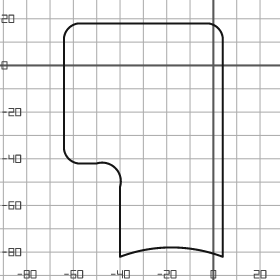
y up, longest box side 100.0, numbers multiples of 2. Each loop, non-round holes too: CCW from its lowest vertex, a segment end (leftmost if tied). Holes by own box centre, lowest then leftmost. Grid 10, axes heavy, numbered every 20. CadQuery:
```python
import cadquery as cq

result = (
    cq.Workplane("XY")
    .moveTo(-40.0, -82.0)
    .threePointArc((-18.0, -78.0), (4.0, -82.0))
    .lineTo(4.0, 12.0)
    .threePointArc((2.0, 16.0), (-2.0, 18.0))
    .lineTo(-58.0, 18.0)
    .threePointArc((-62.0, 16.0), (-64.0, 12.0))
    .lineTo(-64.0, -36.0)
    .threePointArc((-62.0, -40.0), (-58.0, -42.0))
    .lineTo(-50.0, -42.0)
    .threePointArc((-42.0, -44.0), (-40.0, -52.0))
    .close()
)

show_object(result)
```